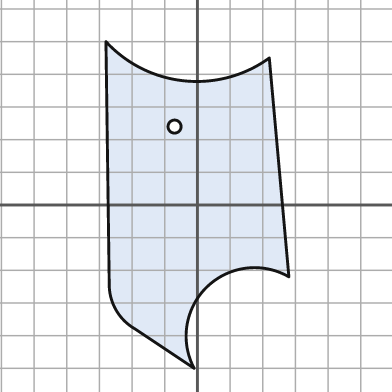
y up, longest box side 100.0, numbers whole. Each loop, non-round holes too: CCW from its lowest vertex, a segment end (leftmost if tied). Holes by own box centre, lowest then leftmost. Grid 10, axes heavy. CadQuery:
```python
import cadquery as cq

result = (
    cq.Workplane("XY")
    .moveTo(-1.0, -50.0)
    .threePointArc((3.0, -25.0), (28.0, -22.0))
    .lineTo(22.0, 45.0)
    .threePointArc((-4.0, 38.0), (-28.0, 50.0))
    .lineTo(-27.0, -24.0)
    .threePointArc((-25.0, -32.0), (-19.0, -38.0))
    .close()
    .moveTo(-7.0, 24.0)
    .circle(2.0)
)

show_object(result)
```